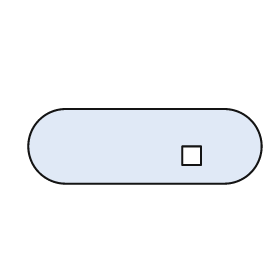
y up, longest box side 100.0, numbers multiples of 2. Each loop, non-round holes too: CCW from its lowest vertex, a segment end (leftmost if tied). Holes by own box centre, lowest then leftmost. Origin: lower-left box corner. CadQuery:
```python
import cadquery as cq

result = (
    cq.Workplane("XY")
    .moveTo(16.0, 0.0)
    .lineTo(84.0, 0.0)
    .threePointArc((100.0, 16.0), (84.0, 32.0))
    .lineTo(16.0, 32.0)
    .threePointArc((0.0, 16.0), (16.0, 0.0))
    .close()
    .moveTo(66.0, 8.0)
    .lineTo(74.0, 8.0)
    .lineTo(74.0, 16.0)
    .lineTo(66.0, 16.0)
    .close()
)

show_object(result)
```